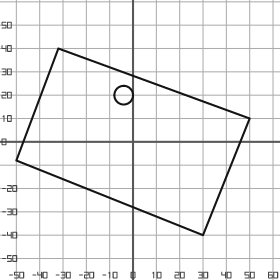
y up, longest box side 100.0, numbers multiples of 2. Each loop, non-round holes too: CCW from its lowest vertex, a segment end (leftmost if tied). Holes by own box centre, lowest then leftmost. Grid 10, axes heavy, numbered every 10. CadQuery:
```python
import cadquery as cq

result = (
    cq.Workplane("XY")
    .moveTo(30.0, -40.0)
    .lineTo(50.0, 10.0)
    .lineTo(-32.0, 40.0)
    .lineTo(-50.0, -8.0)
    .close()
    .moveTo(-4.0, 20.0)
    .circle(4.0)
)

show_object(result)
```